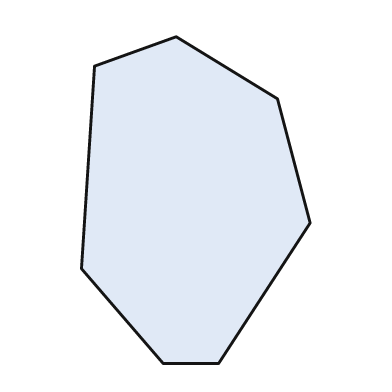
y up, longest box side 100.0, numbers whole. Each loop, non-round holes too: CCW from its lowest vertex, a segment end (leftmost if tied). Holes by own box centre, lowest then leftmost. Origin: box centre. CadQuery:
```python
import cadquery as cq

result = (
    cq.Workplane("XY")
    .moveTo(-10.0, -50.0)
    .lineTo(7.0, -50.0)
    .lineTo(35.0, -7.0)
    .lineTo(25.0, 31.0)
    .lineTo(-6.0, 50.0)
    .lineTo(-31.0, 41.0)
    .lineTo(-35.0, -21.0)
    .close()
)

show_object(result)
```